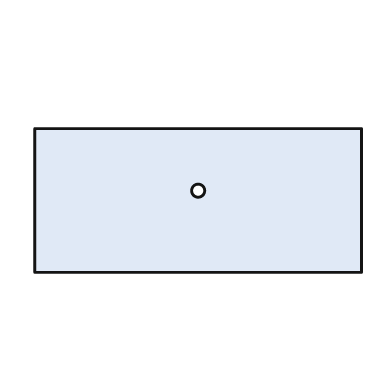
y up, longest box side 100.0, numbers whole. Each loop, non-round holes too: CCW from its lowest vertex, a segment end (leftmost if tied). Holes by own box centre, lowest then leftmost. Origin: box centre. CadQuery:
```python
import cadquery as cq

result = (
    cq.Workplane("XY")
    .moveTo(-50.0, -22.0)
    .lineTo(50.0, -22.0)
    .lineTo(50.0, 22.0)
    .lineTo(-50.0, 22.0)
    .close()
    .moveTo(0.0, 3.0)
    .circle(2.0)
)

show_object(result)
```